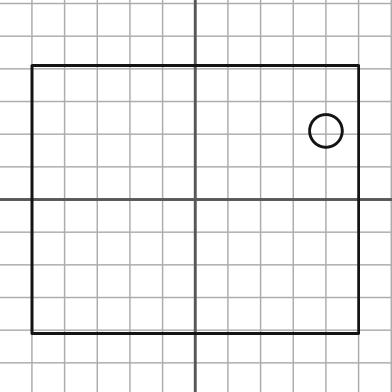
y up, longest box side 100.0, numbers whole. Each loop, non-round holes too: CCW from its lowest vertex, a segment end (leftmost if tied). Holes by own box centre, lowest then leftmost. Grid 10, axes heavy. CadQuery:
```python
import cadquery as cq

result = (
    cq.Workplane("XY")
    .moveTo(-50.0, -41.0)
    .lineTo(50.0, -41.0)
    .lineTo(50.0, 41.0)
    .lineTo(-50.0, 41.0)
    .close()
    .moveTo(40.0, 21.0)
    .circle(5.0)
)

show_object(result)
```